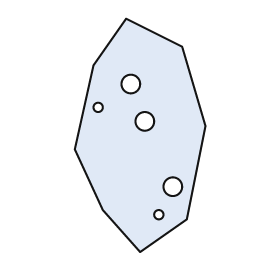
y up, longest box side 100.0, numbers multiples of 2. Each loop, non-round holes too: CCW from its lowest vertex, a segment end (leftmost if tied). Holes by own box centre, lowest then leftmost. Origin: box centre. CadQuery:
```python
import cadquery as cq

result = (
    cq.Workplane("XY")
    .moveTo(0.0, -50.0)
    .lineTo(20.0, -36.0)
    .lineTo(28.0, 4.0)
    .lineTo(18.0, 38.0)
    .lineTo(-6.0, 50.0)
    .lineTo(-20.0, 30.0)
    .lineTo(-28.0, -6.0)
    .lineTo(-16.0, -32.0)
    .close()
    .moveTo(8.0, -34.0)
    .circle(2.0)
    .moveTo(14.0, -22.0)
    .circle(4.0)
    .moveTo(2.0, 6.0)
    .circle(4.0)
    .moveTo(-18.0, 12.0)
    .circle(2.0)
    .moveTo(-4.0, 22.0)
    .circle(4.0)
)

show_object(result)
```